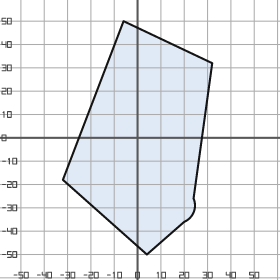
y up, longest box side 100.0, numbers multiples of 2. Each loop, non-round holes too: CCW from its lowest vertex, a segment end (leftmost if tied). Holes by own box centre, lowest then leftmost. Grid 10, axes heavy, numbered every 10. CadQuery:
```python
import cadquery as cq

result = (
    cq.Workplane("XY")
    .moveTo(4.0, -50.0)
    .lineTo(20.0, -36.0)
    .threePointArc((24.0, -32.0), (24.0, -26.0))
    .lineTo(32.0, 32.0)
    .lineTo(-6.0, 50.0)
    .lineTo(-32.0, -18.0)
    .close()
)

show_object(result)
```